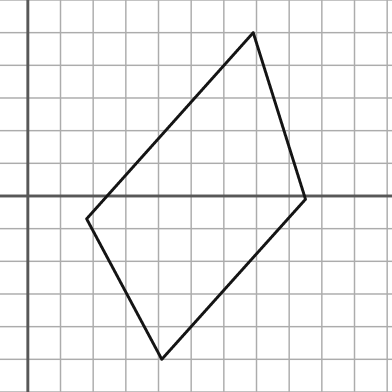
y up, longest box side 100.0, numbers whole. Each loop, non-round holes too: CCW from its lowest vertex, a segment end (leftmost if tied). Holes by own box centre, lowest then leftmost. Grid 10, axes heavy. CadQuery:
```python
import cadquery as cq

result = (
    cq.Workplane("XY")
    .moveTo(41.0, -50.0)
    .lineTo(85.0, -1.0)
    .lineTo(69.0, 50.0)
    .lineTo(18.0, -7.0)
    .close()
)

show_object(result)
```